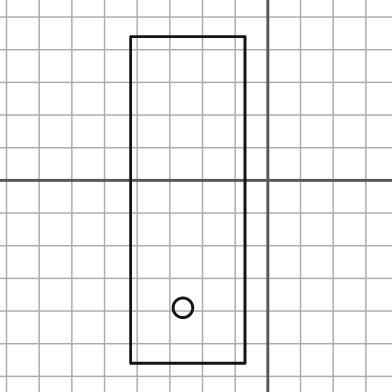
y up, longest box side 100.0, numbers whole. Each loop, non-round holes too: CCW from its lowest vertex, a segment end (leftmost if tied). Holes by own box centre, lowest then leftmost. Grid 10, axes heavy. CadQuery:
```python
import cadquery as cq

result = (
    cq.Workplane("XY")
    .moveTo(-42.0, -56.0)
    .lineTo(-7.0, -56.0)
    .lineTo(-7.0, 44.0)
    .lineTo(-42.0, 44.0)
    .close()
    .moveTo(-26.0, -39.0)
    .circle(3.0)
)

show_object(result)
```